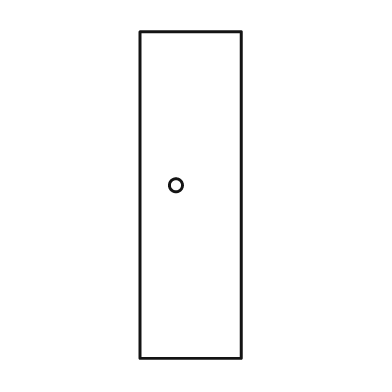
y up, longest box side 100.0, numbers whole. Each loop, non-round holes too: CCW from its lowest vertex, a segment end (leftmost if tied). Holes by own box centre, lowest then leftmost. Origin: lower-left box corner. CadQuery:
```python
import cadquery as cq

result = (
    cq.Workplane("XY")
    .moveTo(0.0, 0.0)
    .lineTo(31.0, 0.0)
    .lineTo(31.0, 100.0)
    .lineTo(0.0, 100.0)
    .close()
    .moveTo(11.0, 53.0)
    .circle(2.0)
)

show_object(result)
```